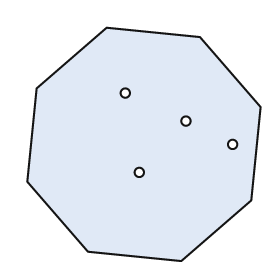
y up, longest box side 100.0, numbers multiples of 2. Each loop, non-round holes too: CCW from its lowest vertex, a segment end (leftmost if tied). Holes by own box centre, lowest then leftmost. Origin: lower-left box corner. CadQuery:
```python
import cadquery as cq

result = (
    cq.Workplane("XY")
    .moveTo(66.0, 0.0)
    .lineTo(96.0, 26.0)
    .lineTo(100.0, 66.0)
    .lineTo(74.0, 96.0)
    .lineTo(34.0, 100.0)
    .lineTo(4.0, 74.0)
    .lineTo(0.0, 34.0)
    .lineTo(26.0, 4.0)
    .close()
    .moveTo(48.0, 38.0)
    .circle(2.0)
    .moveTo(88.0, 50.0)
    .circle(2.0)
    .moveTo(68.0, 60.0)
    .circle(2.0)
    .moveTo(42.0, 72.0)
    .circle(2.0)
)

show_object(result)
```